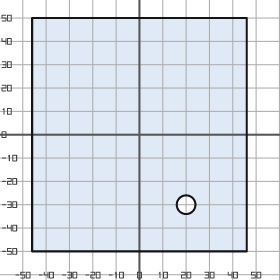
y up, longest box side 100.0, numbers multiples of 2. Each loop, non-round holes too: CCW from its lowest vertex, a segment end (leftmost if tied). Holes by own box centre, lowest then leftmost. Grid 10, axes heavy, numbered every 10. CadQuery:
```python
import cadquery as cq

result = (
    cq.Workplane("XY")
    .moveTo(-46.0, -50.0)
    .lineTo(46.0, -50.0)
    .lineTo(46.0, 50.0)
    .lineTo(-46.0, 50.0)
    .close()
    .moveTo(20.0, -30.0)
    .circle(4.0)
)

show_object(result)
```